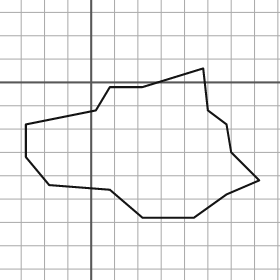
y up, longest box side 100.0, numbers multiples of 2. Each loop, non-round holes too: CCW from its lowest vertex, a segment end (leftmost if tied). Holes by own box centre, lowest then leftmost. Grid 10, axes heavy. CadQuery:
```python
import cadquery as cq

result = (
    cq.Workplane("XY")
    .moveTo(22.0, -58.0)
    .lineTo(44.0, -58.0)
    .lineTo(58.0, -48.0)
    .lineTo(72.0, -42.0)
    .lineTo(60.0, -30.0)
    .lineTo(58.0, -18.0)
    .lineTo(50.0, -12.0)
    .lineTo(48.0, 6.0)
    .lineTo(22.0, -2.0)
    .lineTo(8.0, -2.0)
    .lineTo(2.0, -12.0)
    .lineTo(-28.0, -18.0)
    .lineTo(-28.0, -32.0)
    .lineTo(-18.0, -44.0)
    .lineTo(8.0, -46.0)
    .close()
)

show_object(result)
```